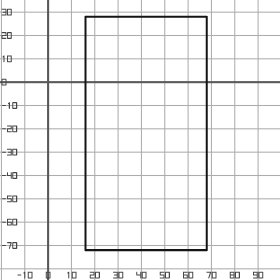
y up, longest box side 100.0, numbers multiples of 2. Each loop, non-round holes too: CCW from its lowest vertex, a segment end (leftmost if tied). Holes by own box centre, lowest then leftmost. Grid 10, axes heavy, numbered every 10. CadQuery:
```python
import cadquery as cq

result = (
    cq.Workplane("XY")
    .moveTo(16.0, -72.0)
    .lineTo(68.0, -72.0)
    .lineTo(68.0, 28.0)
    .lineTo(16.0, 28.0)
    .close()
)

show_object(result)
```